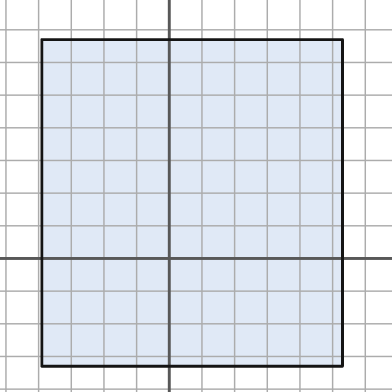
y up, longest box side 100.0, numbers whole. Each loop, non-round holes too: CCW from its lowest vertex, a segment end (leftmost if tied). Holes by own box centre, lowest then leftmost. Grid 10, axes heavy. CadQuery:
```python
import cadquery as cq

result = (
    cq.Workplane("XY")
    .moveTo(-39.0, -33.0)
    .lineTo(53.0, -33.0)
    .lineTo(53.0, 67.0)
    .lineTo(-39.0, 67.0)
    .close()
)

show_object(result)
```